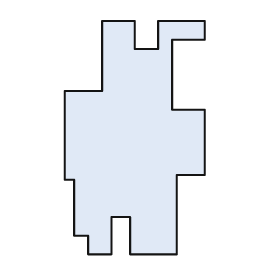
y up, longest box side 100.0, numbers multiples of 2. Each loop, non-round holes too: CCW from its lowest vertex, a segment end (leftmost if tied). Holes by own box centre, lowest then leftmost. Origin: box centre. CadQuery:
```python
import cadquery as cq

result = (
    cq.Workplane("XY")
    .moveTo(-20.0, -50.0)
    .lineTo(-10.0, -50.0)
    .lineTo(-10.0, -34.0)
    .lineTo(-2.0, -34.0)
    .lineTo(-2.0, -50.0)
    .lineTo(18.0, -50.0)
    .lineTo(18.0, -16.0)
    .lineTo(30.0, -16.0)
    .lineTo(30.0, 12.0)
    .lineTo(16.0, 12.0)
    .lineTo(16.0, 42.0)
    .lineTo(30.0, 42.0)
    .lineTo(30.0, 50.0)
    .lineTo(10.0, 50.0)
    .lineTo(10.0, 38.0)
    .lineTo(0.0, 38.0)
    .lineTo(0.0, 50.0)
    .lineTo(-14.0, 50.0)
    .lineTo(-14.0, 20.0)
    .lineTo(-30.0, 20.0)
    .lineTo(-30.0, -18.0)
    .lineTo(-26.0, -18.0)
    .lineTo(-26.0, -42.0)
    .lineTo(-20.0, -42.0)
    .close()
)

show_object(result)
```